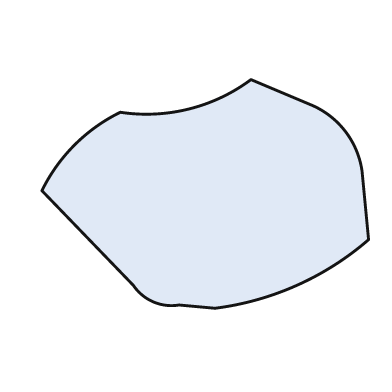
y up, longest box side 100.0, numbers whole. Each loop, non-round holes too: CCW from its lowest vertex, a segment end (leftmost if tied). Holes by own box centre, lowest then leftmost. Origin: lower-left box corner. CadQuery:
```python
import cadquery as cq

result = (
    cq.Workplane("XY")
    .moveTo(53.0, 0.0)
    .threePointArc((78.0, 7.0), (100.0, 21.0))
    .lineTo(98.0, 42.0)
    .threePointArc((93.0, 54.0), (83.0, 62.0))
    .lineTo(64.0, 70.0)
    .threePointArc((45.0, 61.0), (24.0, 60.0))
    .threePointArc((10.0, 50.0), (0.0, 36.0))
    .lineTo(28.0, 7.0)
    .threePointArc((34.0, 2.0), (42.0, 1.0))
    .close()
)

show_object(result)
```